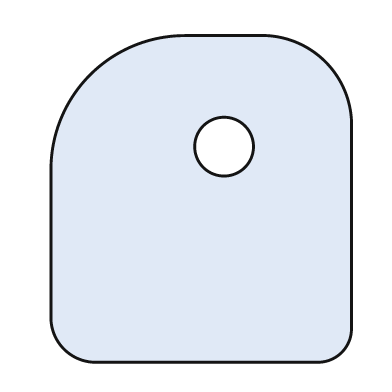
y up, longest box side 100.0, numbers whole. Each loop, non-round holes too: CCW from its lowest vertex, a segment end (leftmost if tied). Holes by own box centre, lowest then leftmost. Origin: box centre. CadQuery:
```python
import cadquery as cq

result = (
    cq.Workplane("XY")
    .moveTo(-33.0, -50.0)
    .lineTo(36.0, -50.0)
    .threePointArc((43.0, -47.0), (46.0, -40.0))
    .lineTo(46.0, 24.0)
    .threePointArc((38.0, 42.0), (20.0, 50.0))
    .lineTo(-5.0, 50.0)
    .threePointArc((-34.0, 38.0), (-46.0, 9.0))
    .lineTo(-46.0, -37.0)
    .threePointArc((-42.0, -46.0), (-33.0, -50.0))
    .close()
    .moveTo(7.0, 16.0)
    .circle(9.0)
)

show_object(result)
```